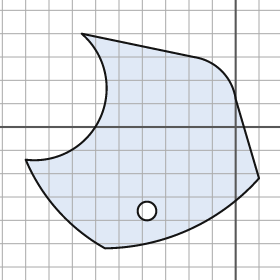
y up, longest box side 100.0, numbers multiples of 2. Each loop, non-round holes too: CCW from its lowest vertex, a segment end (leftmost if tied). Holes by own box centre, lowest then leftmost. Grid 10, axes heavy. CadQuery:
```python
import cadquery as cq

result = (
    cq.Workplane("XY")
    .moveTo(-56.0, -52.0)
    .threePointArc((-20.0, -44.0), (10.0, -22.0))
    .lineTo(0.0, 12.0)
    .threePointArc((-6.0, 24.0), (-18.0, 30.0))
    .lineTo(-66.0, 40.0)
    .threePointArc((-58.0, 4.0), (-90.0, -14.0))
    .threePointArc((-76.0, -36.0), (-56.0, -52.0))
    .close()
    .moveTo(-38.0, -36.0)
    .circle(4.0)
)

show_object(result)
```